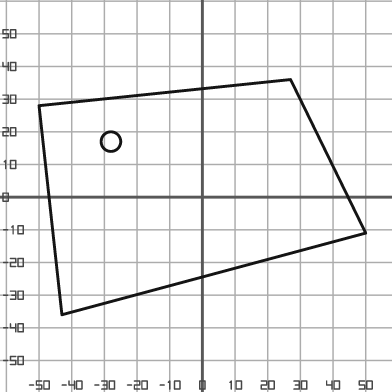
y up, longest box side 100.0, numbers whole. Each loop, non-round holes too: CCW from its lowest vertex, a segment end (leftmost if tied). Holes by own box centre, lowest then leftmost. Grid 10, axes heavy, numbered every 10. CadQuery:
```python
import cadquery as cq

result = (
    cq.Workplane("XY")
    .moveTo(-43.0, -36.0)
    .lineTo(50.0, -11.0)
    .lineTo(27.0, 36.0)
    .lineTo(-50.0, 28.0)
    .close()
    .moveTo(-28.0, 17.0)
    .circle(3.0)
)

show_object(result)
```